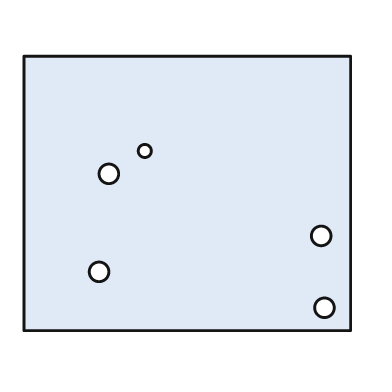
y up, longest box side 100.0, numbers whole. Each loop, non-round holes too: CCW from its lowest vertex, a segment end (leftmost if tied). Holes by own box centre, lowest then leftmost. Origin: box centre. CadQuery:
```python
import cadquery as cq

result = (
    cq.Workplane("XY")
    .moveTo(-50.0, -42.0)
    .lineTo(50.0, -42.0)
    .lineTo(50.0, 42.0)
    .lineTo(-50.0, 42.0)
    .close()
    .moveTo(42.0, -35.0)
    .circle(3.0)
    .moveTo(-27.0, -24.0)
    .circle(3.0)
    .moveTo(41.0, -13.0)
    .circle(3.0)
    .moveTo(-24.0, 6.0)
    .circle(3.0)
    .moveTo(-13.0, 13.0)
    .circle(2.0)
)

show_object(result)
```